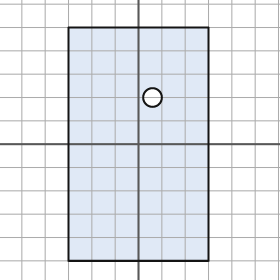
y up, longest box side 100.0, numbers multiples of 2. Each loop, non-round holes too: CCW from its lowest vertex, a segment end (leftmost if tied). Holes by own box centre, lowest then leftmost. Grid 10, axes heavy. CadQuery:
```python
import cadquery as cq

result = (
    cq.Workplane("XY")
    .moveTo(-30.0, -50.0)
    .lineTo(30.0, -50.0)
    .lineTo(30.0, 50.0)
    .lineTo(-30.0, 50.0)
    .close()
    .moveTo(6.0, 20.0)
    .circle(4.0)
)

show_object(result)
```